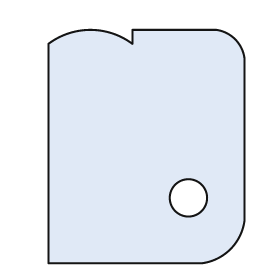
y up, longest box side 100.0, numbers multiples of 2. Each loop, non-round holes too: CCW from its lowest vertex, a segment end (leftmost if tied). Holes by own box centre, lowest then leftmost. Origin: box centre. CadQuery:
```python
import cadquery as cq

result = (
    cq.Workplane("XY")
    .moveTo(-42.0, -50.0)
    .lineTo(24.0, -50.0)
    .threePointArc((36.0, -44.0), (42.0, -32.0))
    .lineTo(42.0, 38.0)
    .threePointArc((38.0, 46.0), (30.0, 50.0))
    .lineTo(-6.0, 50.0)
    .lineTo(-6.0, 44.0)
    .threePointArc((-24.0, 50.0), (-42.0, 44.0))
    .close()
    .moveTo(18.0, -22.0)
    .circle(8.0)
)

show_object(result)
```